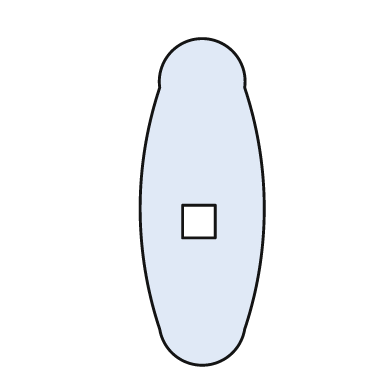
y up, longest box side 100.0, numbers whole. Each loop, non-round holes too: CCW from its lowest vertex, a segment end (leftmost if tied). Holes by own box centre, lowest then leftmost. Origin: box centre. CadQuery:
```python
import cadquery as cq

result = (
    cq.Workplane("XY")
    .moveTo(-13.0, -39.0)
    .threePointArc((0.0, -50.0), (13.0, -39.0))
    .threePointArc((19.0, -2.0), (13.0, 35.0))
    .threePointArc((0.0, 50.0), (-13.0, 35.0))
    .threePointArc((-19.0, -2.0), (-13.0, -39.0))
    .close()
    .moveTo(-6.0, -11.0)
    .lineTo(4.0, -11.0)
    .lineTo(4.0, -1.0)
    .lineTo(-6.0, -1.0)
    .close()
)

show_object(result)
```